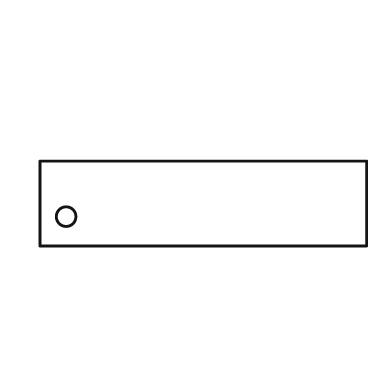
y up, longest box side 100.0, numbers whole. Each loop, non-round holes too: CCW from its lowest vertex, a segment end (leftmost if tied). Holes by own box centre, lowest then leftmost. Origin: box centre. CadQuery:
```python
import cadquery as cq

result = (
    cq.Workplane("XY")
    .moveTo(-50.0, -13.0)
    .lineTo(50.0, -13.0)
    .lineTo(50.0, 13.0)
    .lineTo(-50.0, 13.0)
    .close()
    .moveTo(-42.0, -4.0)
    .circle(3.0)
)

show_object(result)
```